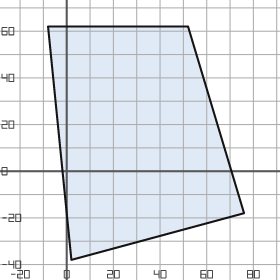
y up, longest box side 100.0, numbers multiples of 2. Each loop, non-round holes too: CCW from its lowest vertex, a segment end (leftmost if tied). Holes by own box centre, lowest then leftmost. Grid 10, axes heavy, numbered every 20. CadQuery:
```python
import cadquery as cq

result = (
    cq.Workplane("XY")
    .moveTo(2.0, -38.0)
    .lineTo(76.0, -18.0)
    .lineTo(52.0, 62.0)
    .lineTo(-8.0, 62.0)
    .close()
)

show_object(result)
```